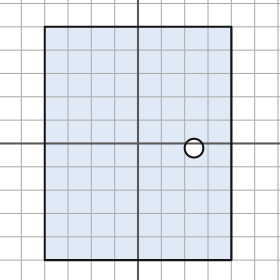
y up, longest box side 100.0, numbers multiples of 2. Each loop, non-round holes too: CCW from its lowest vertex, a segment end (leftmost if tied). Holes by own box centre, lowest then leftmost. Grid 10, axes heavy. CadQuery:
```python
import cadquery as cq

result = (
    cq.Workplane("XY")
    .moveTo(-40.0, -50.0)
    .lineTo(40.0, -50.0)
    .lineTo(40.0, 50.0)
    .lineTo(-40.0, 50.0)
    .close()
    .moveTo(24.0, -2.0)
    .circle(4.0)
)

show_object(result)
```